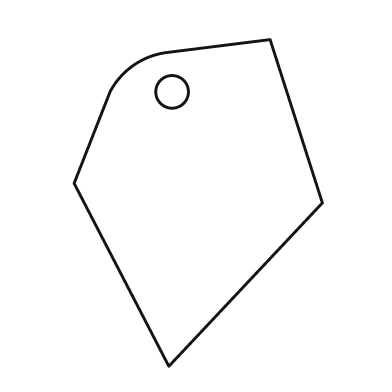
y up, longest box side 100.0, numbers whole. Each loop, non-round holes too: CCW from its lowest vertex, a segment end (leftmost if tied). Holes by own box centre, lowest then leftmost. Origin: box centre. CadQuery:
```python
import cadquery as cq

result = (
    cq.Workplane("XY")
    .moveTo(-9.0, -50.0)
    .lineTo(38.0, 0.0)
    .lineTo(22.0, 50.0)
    .lineTo(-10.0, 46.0)
    .threePointArc((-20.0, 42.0), (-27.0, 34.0))
    .lineTo(-38.0, 6.0)
    .close()
    .moveTo(-8.0, 34.0)
    .circle(5.0)
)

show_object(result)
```